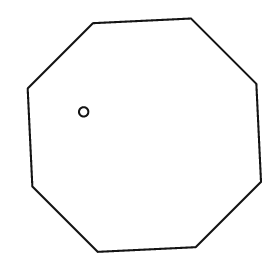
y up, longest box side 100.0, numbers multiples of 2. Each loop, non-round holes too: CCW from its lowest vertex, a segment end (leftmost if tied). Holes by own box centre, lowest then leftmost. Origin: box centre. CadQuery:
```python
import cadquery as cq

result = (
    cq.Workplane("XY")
    .moveTo(-20.0, -50.0)
    .lineTo(22.0, -48.0)
    .lineTo(50.0, -20.0)
    .lineTo(48.0, 22.0)
    .lineTo(20.0, 50.0)
    .lineTo(-22.0, 48.0)
    .lineTo(-50.0, 20.0)
    .lineTo(-48.0, -22.0)
    .close()
    .moveTo(-26.0, 10.0)
    .circle(2.0)
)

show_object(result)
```